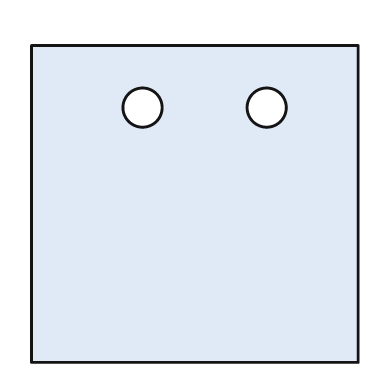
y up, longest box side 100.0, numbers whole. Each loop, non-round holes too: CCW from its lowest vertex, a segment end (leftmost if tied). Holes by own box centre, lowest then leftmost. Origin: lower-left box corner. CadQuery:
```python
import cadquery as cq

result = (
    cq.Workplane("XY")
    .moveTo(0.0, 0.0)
    .lineTo(100.0, 0.0)
    .lineTo(100.0, 97.0)
    .lineTo(0.0, 97.0)
    .close()
    .moveTo(34.0, 78.0)
    .circle(6.0)
    .moveTo(72.0, 78.0)
    .circle(6.0)
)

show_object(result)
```